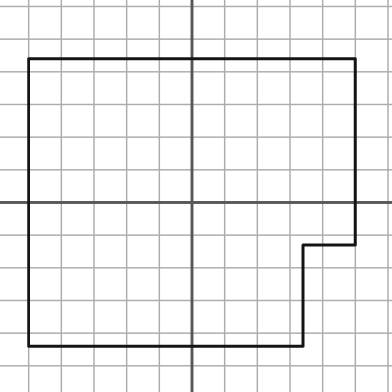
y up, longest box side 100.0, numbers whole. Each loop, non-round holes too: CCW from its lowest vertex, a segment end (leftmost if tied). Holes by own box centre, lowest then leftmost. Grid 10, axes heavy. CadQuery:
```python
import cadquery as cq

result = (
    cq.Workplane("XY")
    .moveTo(-50.0, -44.0)
    .lineTo(34.0, -44.0)
    .lineTo(34.0, -13.0)
    .lineTo(50.0, -13.0)
    .lineTo(50.0, 44.0)
    .lineTo(-50.0, 44.0)
    .close()
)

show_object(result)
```